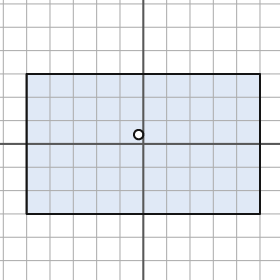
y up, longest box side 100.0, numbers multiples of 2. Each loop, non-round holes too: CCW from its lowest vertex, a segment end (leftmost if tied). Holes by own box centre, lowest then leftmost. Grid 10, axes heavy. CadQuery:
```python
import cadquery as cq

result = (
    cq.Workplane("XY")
    .moveTo(-50.0, -30.0)
    .lineTo(50.0, -30.0)
    .lineTo(50.0, 30.0)
    .lineTo(-50.0, 30.0)
    .close()
    .moveTo(-2.0, 4.0)
    .circle(2.0)
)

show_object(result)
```